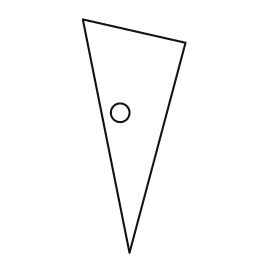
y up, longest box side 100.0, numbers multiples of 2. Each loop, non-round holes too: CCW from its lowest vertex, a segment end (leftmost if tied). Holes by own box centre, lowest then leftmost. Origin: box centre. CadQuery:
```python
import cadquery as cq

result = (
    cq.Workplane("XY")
    .moveTo(-2.0, -50.0)
    .lineTo(22.0, 40.0)
    .lineTo(-22.0, 50.0)
    .close()
    .moveTo(-6.0, 10.0)
    .circle(4.0)
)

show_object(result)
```